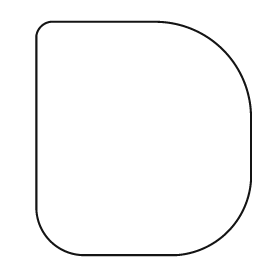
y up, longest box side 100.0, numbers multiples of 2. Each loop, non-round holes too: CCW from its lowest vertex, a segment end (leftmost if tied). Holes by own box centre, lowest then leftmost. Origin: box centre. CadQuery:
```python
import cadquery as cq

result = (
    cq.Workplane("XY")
    .moveTo(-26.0, -50.0)
    .lineTo(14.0, -50.0)
    .threePointArc((36.0, -40.0), (46.0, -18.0))
    .lineTo(46.0, 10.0)
    .threePointArc((34.0, 38.0), (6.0, 50.0))
    .lineTo(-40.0, 50.0)
    .threePointArc((-44.0, 48.0), (-46.0, 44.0))
    .lineTo(-46.0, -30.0)
    .threePointArc((-40.0, -44.0), (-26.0, -50.0))
    .close()
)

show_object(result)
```